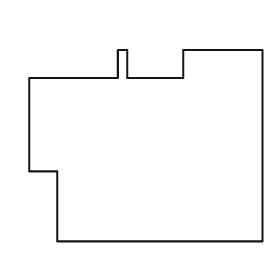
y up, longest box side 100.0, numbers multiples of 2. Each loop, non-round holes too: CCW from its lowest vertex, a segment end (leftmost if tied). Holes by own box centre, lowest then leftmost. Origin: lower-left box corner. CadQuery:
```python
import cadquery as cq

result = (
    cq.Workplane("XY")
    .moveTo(12.0, 0.0)
    .lineTo(100.0, 0.0)
    .lineTo(100.0, 82.0)
    .lineTo(66.0, 82.0)
    .lineTo(66.0, 70.0)
    .lineTo(42.0, 70.0)
    .lineTo(42.0, 82.0)
    .lineTo(38.0, 82.0)
    .lineTo(38.0, 70.0)
    .lineTo(0.0, 70.0)
    .lineTo(0.0, 30.0)
    .lineTo(12.0, 30.0)
    .close()
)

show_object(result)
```